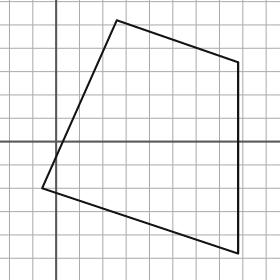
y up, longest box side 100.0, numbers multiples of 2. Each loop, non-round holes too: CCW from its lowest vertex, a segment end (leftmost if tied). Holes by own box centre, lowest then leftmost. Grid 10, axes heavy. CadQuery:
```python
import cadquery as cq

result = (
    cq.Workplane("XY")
    .moveTo(78.0, -48.0)
    .lineTo(78.0, 34.0)
    .lineTo(26.0, 52.0)
    .lineTo(-6.0, -20.0)
    .close()
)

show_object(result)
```